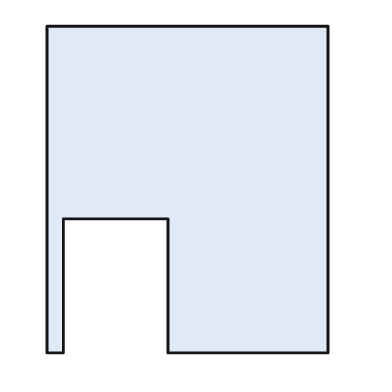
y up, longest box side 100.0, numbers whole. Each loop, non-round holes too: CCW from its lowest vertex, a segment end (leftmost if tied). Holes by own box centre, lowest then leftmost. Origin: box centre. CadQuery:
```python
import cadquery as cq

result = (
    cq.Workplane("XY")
    .moveTo(-43.0, -50.0)
    .lineTo(-38.0, -50.0)
    .lineTo(-38.0, -9.0)
    .lineTo(-6.0, -9.0)
    .lineTo(-6.0, -50.0)
    .lineTo(43.0, -50.0)
    .lineTo(43.0, 50.0)
    .lineTo(-43.0, 50.0)
    .close()
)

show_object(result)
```